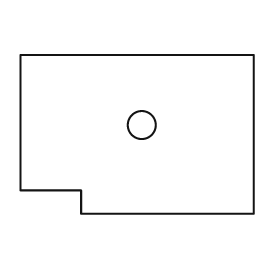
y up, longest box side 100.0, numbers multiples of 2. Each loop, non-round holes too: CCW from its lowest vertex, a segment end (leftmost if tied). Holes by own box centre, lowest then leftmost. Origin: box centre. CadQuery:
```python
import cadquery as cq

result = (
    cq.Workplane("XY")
    .moveTo(-24.0, -34.0)
    .lineTo(50.0, -34.0)
    .lineTo(50.0, 34.0)
    .lineTo(-50.0, 34.0)
    .lineTo(-50.0, -24.0)
    .lineTo(-24.0, -24.0)
    .close()
    .moveTo(2.0, 4.0)
    .circle(6.0)
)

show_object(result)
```